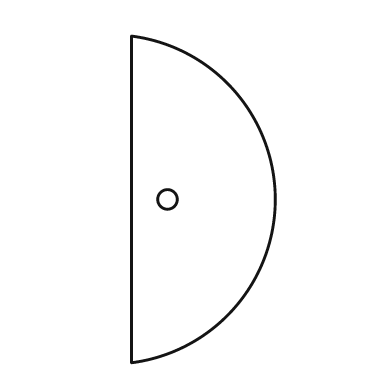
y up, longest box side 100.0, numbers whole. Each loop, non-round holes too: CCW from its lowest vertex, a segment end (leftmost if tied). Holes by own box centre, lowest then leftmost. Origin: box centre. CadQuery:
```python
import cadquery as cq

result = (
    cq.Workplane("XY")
    .moveTo(-22.0, -50.0)
    .threePointArc((22.0, 0.0), (-22.0, 50.0))
    .close()
    .moveTo(-11.0, 0.0)
    .circle(3.0)
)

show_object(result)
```